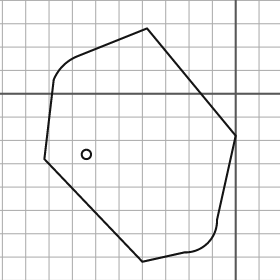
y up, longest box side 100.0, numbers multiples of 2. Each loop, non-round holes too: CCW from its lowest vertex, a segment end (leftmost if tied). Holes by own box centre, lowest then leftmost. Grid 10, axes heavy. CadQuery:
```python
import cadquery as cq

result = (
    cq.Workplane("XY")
    .moveTo(-40.0, -72.0)
    .lineTo(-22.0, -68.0)
    .threePointArc((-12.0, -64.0), (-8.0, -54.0))
    .lineTo(0.0, -18.0)
    .lineTo(-38.0, 28.0)
    .lineTo(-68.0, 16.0)
    .threePointArc((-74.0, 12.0), (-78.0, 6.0))
    .lineTo(-82.0, -28.0)
    .close()
    .moveTo(-64.0, -26.0)
    .circle(2.0)
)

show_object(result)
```